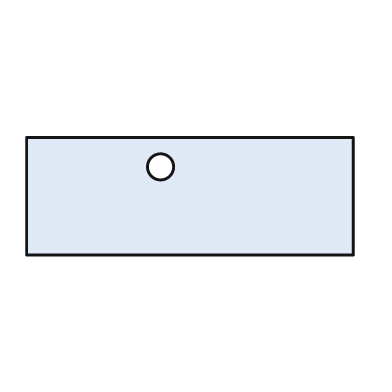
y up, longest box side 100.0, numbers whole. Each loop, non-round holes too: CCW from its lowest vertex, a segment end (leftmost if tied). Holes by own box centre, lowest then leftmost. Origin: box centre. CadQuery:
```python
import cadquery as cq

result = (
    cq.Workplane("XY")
    .moveTo(-50.0, -18.0)
    .lineTo(50.0, -18.0)
    .lineTo(50.0, 18.0)
    .lineTo(-50.0, 18.0)
    .close()
    .moveTo(-9.0, 9.0)
    .circle(4.0)
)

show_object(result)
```